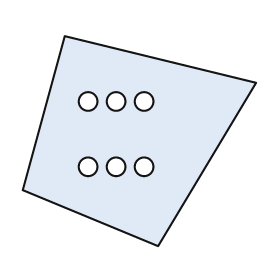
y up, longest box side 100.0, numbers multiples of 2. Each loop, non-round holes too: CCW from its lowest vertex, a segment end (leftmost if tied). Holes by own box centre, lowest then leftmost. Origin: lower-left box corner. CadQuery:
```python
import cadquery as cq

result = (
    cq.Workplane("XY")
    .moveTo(58.0, 0.0)
    .lineTo(100.0, 70.0)
    .lineTo(18.0, 90.0)
    .lineTo(0.0, 24.0)
    .close()
    .moveTo(28.0, 34.0)
    .circle(4.0)
    .moveTo(40.0, 34.0)
    .circle(4.0)
    .moveTo(52.0, 34.0)
    .circle(4.0)
    .moveTo(28.0, 62.0)
    .circle(4.0)
    .moveTo(40.0, 62.0)
    .circle(4.0)
    .moveTo(52.0, 62.0)
    .circle(4.0)
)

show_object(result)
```